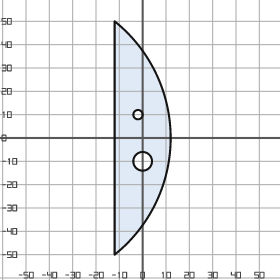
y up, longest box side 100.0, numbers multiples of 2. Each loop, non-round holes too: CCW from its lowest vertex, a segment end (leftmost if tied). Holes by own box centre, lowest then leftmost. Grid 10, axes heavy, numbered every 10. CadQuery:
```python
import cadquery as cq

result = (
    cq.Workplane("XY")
    .moveTo(-12.0, -50.0)
    .threePointArc((12.0, 0.0), (-12.0, 50.0))
    .close()
    .moveTo(0.0, -10.0)
    .circle(4.0)
    .moveTo(-2.0, 10.0)
    .circle(2.0)
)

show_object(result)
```